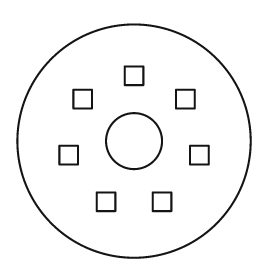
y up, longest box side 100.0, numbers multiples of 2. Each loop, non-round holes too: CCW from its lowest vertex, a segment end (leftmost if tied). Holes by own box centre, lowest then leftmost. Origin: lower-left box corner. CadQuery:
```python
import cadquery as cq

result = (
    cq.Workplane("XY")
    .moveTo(50.0, 50.0)
    .circle(50.0)
    .moveTo(34.0, 20.0)
    .lineTo(42.0, 20.0)
    .lineTo(42.0, 28.0)
    .lineTo(34.0, 28.0)
    .close()
    .moveTo(58.0, 20.0)
    .lineTo(66.0, 20.0)
    .lineTo(66.0, 28.0)
    .lineTo(58.0, 28.0)
    .close()
    .moveTo(18.0, 40.0)
    .lineTo(26.0, 40.0)
    .lineTo(26.0, 48.0)
    .lineTo(18.0, 48.0)
    .close()
    .moveTo(74.0, 40.0)
    .lineTo(82.0, 40.0)
    .lineTo(82.0, 48.0)
    .lineTo(74.0, 48.0)
    .close()
    .moveTo(50.0, 50.0)
    .circle(12.0)
    .moveTo(24.0, 64.0)
    .lineTo(32.0, 64.0)
    .lineTo(32.0, 72.0)
    .lineTo(24.0, 72.0)
    .close()
    .moveTo(68.0, 64.0)
    .lineTo(76.0, 64.0)
    .lineTo(76.0, 72.0)
    .lineTo(68.0, 72.0)
    .close()
    .moveTo(46.0, 74.0)
    .lineTo(54.0, 74.0)
    .lineTo(54.0, 82.0)
    .lineTo(46.0, 82.0)
    .close()
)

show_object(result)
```